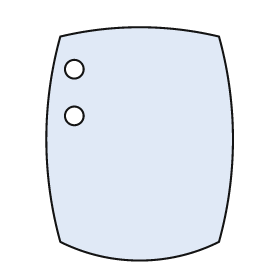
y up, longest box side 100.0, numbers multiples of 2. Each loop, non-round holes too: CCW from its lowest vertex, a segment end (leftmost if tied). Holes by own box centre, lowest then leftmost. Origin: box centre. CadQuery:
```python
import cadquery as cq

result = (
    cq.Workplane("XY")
    .moveTo(-34.0, -42.0)
    .threePointArc((0.0, -50.0), (34.0, -42.0))
    .threePointArc((40.0, 2.0), (34.0, 46.0))
    .threePointArc((0.0, 50.0), (-34.0, 46.0))
    .threePointArc((-40.0, 2.0), (-34.0, -42.0))
    .close()
    .moveTo(-28.0, 12.0)
    .circle(4.0)
    .moveTo(-28.0, 32.0)
    .circle(4.0)
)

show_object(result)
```